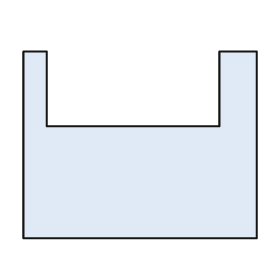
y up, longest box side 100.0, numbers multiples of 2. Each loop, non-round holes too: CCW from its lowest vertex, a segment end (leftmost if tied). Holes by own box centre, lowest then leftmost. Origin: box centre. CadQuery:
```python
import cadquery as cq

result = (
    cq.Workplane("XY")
    .moveTo(-50.0, -40.0)
    .lineTo(50.0, -40.0)
    .lineTo(50.0, 40.0)
    .lineTo(34.0, 40.0)
    .lineTo(34.0, 8.0)
    .lineTo(-40.0, 8.0)
    .lineTo(-40.0, 40.0)
    .lineTo(-50.0, 40.0)
    .close()
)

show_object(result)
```